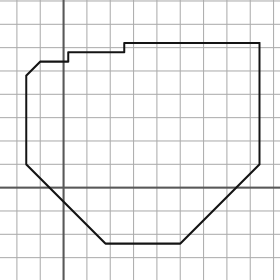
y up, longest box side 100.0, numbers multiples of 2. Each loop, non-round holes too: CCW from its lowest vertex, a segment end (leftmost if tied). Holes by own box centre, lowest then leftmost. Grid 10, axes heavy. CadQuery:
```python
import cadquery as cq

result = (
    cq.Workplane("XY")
    .moveTo(18.0, -24.0)
    .lineTo(50.0, -24.0)
    .lineTo(84.0, 10.0)
    .lineTo(84.0, 62.0)
    .lineTo(26.0, 62.0)
    .lineTo(26.0, 58.0)
    .lineTo(2.0, 58.0)
    .lineTo(2.0, 54.0)
    .lineTo(-10.0, 54.0)
    .lineTo(-16.0, 48.0)
    .lineTo(-16.0, 10.0)
    .close()
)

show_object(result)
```